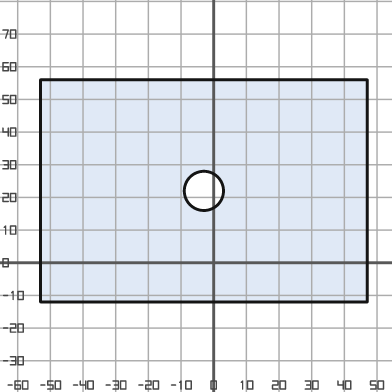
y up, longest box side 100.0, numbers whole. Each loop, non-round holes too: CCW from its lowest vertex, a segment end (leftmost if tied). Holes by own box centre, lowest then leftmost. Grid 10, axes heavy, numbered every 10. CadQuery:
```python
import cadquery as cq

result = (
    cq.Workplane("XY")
    .moveTo(-53.0, -12.0)
    .lineTo(47.0, -12.0)
    .lineTo(47.0, 56.0)
    .lineTo(-53.0, 56.0)
    .close()
    .moveTo(-3.0, 22.0)
    .circle(6.0)
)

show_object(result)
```